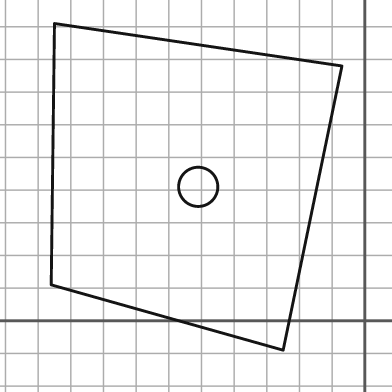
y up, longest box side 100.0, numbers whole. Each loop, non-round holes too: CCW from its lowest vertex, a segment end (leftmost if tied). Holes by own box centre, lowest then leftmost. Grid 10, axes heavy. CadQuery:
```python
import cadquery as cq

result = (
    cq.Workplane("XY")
    .moveTo(-25.0, -9.0)
    .lineTo(-7.0, 78.0)
    .lineTo(-95.0, 91.0)
    .lineTo(-96.0, 11.0)
    .close()
    .moveTo(-51.0, 41.0)
    .circle(6.0)
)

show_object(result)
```